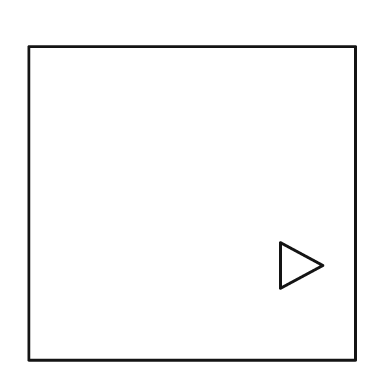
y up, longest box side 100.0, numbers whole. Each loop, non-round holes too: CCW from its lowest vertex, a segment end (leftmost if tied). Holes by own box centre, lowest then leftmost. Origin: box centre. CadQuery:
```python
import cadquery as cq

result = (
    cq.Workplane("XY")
    .moveTo(-50.0, -48.0)
    .lineTo(50.0, -48.0)
    .lineTo(50.0, 48.0)
    .lineTo(-50.0, 48.0)
    .close()
    .moveTo(27.0, -26.0)
    .lineTo(40.0, -19.0)
    .lineTo(27.0, -12.0)
    .close()
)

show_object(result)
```